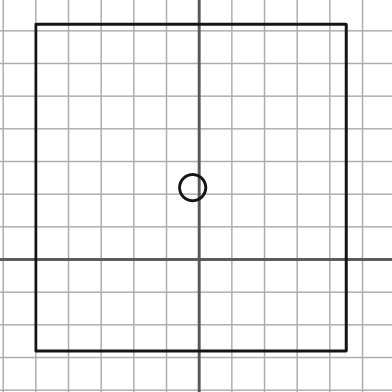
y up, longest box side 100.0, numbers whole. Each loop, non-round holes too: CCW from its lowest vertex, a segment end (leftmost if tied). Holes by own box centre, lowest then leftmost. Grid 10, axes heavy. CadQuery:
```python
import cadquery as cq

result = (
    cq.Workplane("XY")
    .moveTo(-50.0, -28.0)
    .lineTo(45.0, -28.0)
    .lineTo(45.0, 72.0)
    .lineTo(-50.0, 72.0)
    .close()
    .moveTo(-2.0, 22.0)
    .circle(4.0)
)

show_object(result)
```